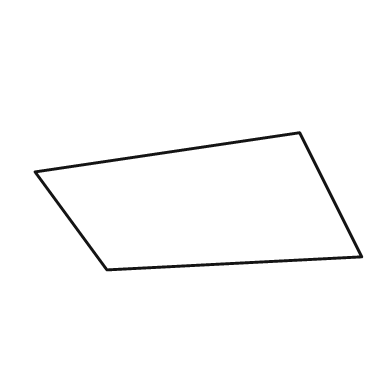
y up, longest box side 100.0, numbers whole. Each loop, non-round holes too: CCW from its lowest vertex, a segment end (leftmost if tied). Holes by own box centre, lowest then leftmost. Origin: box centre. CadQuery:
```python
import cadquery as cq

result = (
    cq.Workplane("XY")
    .moveTo(-28.0, -21.0)
    .lineTo(50.0, -17.0)
    .lineTo(31.0, 21.0)
    .lineTo(-50.0, 9.0)
    .close()
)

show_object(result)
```